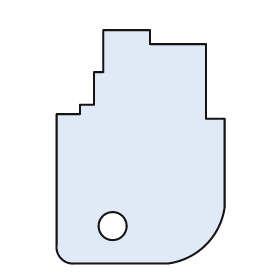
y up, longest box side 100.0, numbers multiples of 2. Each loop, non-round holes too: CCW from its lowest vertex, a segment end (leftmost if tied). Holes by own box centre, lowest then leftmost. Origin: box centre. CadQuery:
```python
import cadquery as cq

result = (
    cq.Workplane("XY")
    .moveTo(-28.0, -50.0)
    .lineTo(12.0, -50.0)
    .threePointArc((28.0, -42.0), (36.0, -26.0))
    .lineTo(36.0, 12.0)
    .lineTo(28.0, 12.0)
    .lineTo(28.0, 44.0)
    .lineTo(4.0, 44.0)
    .lineTo(4.0, 50.0)
    .lineTo(-16.0, 50.0)
    .lineTo(-16.0, 32.0)
    .lineTo(-20.0, 32.0)
    .lineTo(-20.0, 18.0)
    .lineTo(-26.0, 18.0)
    .lineTo(-26.0, 14.0)
    .lineTo(-36.0, 14.0)
    .lineTo(-36.0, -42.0)
    .threePointArc((-34.0, -48.0), (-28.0, -50.0))
    .close()
    .moveTo(-12.0, -34.0)
    .circle(6.0)
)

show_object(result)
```